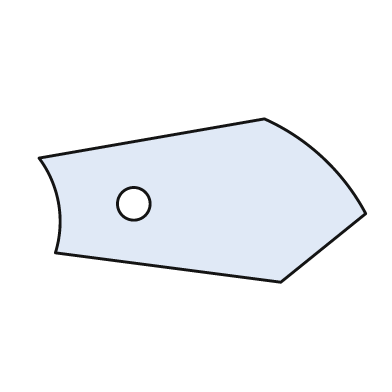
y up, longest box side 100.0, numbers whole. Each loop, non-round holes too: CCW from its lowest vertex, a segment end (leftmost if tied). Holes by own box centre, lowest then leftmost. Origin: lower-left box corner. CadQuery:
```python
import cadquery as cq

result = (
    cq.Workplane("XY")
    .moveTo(74.0, 0.0)
    .lineTo(100.0, 21.0)
    .threePointArc((87.0, 38.0), (69.0, 50.0))
    .lineTo(0.0, 38.0)
    .threePointArc((6.0, 24.0), (5.0, 9.0))
    .close()
    .moveTo(29.0, 24.0)
    .circle(5.0)
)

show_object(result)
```